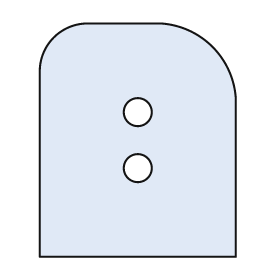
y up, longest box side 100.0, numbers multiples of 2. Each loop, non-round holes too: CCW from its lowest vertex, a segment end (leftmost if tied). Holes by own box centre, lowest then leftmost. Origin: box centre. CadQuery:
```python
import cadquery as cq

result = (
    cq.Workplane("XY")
    .moveTo(-42.0, -50.0)
    .lineTo(42.0, -50.0)
    .lineTo(42.0, 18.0)
    .threePointArc((32.0, 40.0), (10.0, 50.0))
    .lineTo(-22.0, 50.0)
    .threePointArc((-36.0, 44.0), (-42.0, 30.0))
    .close()
    .moveTo(0.0, -12.0)
    .circle(6.0)
    .moveTo(0.0, 12.0)
    .circle(6.0)
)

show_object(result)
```